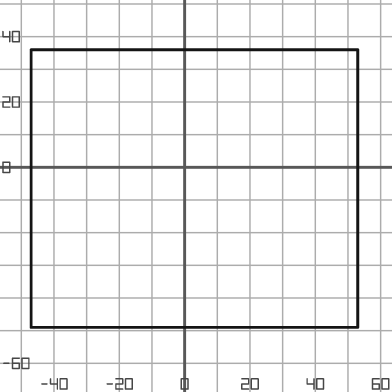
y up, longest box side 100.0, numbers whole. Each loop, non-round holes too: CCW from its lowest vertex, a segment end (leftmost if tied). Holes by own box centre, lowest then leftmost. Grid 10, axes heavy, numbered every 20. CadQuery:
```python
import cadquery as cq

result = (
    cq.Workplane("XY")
    .moveTo(-47.0, -49.0)
    .lineTo(53.0, -49.0)
    .lineTo(53.0, 36.0)
    .lineTo(-47.0, 36.0)
    .close()
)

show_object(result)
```